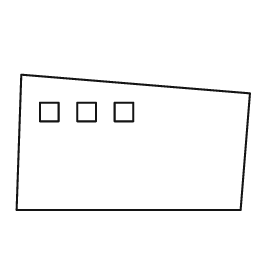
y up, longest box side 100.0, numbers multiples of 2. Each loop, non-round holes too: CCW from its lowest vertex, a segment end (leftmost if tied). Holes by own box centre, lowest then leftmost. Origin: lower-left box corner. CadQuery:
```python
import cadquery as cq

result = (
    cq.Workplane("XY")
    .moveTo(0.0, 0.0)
    .lineTo(96.0, 0.0)
    .lineTo(100.0, 50.0)
    .lineTo(2.0, 58.0)
    .close()
    .moveTo(10.0, 38.0)
    .lineTo(18.0, 38.0)
    .lineTo(18.0, 46.0)
    .lineTo(10.0, 46.0)
    .close()
    .moveTo(26.0, 38.0)
    .lineTo(34.0, 38.0)
    .lineTo(34.0, 46.0)
    .lineTo(26.0, 46.0)
    .close()
    .moveTo(42.0, 38.0)
    .lineTo(50.0, 38.0)
    .lineTo(50.0, 46.0)
    .lineTo(42.0, 46.0)
    .close()
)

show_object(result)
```